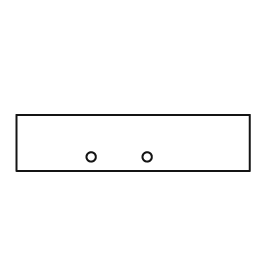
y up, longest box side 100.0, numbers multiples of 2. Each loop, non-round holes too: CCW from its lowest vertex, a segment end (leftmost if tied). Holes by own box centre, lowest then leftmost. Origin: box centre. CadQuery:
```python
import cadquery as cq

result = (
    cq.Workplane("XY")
    .moveTo(-50.0, -12.0)
    .lineTo(50.0, -12.0)
    .lineTo(50.0, 12.0)
    .lineTo(-50.0, 12.0)
    .close()
    .moveTo(-18.0, -6.0)
    .circle(2.0)
    .moveTo(6.0, -6.0)
    .circle(2.0)
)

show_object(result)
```